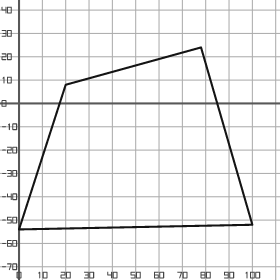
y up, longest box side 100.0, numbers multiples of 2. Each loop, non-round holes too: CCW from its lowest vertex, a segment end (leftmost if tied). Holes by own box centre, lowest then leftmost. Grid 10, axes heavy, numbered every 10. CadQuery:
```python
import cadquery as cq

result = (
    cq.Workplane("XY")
    .moveTo(0.0, -54.0)
    .lineTo(100.0, -52.0)
    .lineTo(78.0, 24.0)
    .lineTo(20.0, 8.0)
    .close()
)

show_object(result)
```